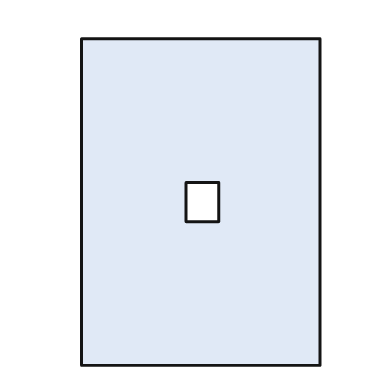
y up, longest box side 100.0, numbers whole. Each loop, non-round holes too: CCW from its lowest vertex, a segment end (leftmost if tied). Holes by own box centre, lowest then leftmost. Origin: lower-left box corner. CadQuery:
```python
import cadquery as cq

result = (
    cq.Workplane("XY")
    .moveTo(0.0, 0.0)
    .lineTo(73.0, 0.0)
    .lineTo(73.0, 100.0)
    .lineTo(0.0, 100.0)
    .close()
    .moveTo(32.0, 44.0)
    .lineTo(42.0, 44.0)
    .lineTo(42.0, 56.0)
    .lineTo(32.0, 56.0)
    .close()
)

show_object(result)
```